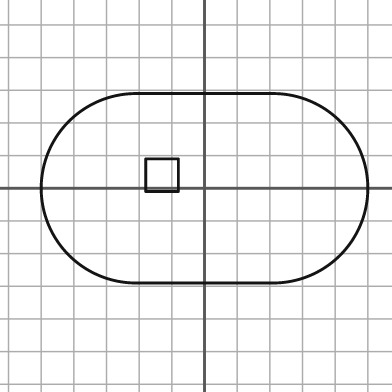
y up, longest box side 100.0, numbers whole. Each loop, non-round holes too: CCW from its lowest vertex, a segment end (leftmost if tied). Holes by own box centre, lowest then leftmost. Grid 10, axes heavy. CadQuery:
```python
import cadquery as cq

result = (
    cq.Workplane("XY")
    .moveTo(-21.0, -29.0)
    .lineTo(21.0, -29.0)
    .threePointArc((50.0, 0.0), (21.0, 29.0))
    .lineTo(-21.0, 29.0)
    .threePointArc((-50.0, 0.0), (-21.0, -29.0))
    .close()
    .moveTo(-18.0, -1.0)
    .lineTo(-8.0, -1.0)
    .lineTo(-8.0, 9.0)
    .lineTo(-18.0, 9.0)
    .close()
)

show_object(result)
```